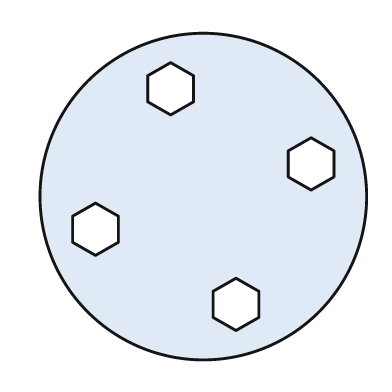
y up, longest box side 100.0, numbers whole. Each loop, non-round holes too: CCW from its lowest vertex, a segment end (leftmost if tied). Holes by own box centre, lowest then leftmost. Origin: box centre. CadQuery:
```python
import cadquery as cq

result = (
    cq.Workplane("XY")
    .moveTo(0.0, 0.0)
    .circle(50.0)
    .moveTo(10.0, -41.0)
    .lineTo(17.0, -37.0)
    .lineTo(17.0, -29.0)
    .lineTo(10.0, -25.0)
    .lineTo(3.0, -29.0)
    .lineTo(3.0, -37.0)
    .close()
    .moveTo(-33.0, -18.0)
    .lineTo(-26.0, -14.0)
    .lineTo(-26.0, -6.0)
    .lineTo(-33.0, -2.0)
    .lineTo(-40.0, -6.0)
    .lineTo(-40.0, -14.0)
    .close()
    .moveTo(33.0, 2.0)
    .lineTo(40.0, 6.0)
    .lineTo(40.0, 14.0)
    .lineTo(33.0, 18.0)
    .lineTo(26.0, 14.0)
    .lineTo(26.0, 6.0)
    .close()
    .moveTo(-10.0, 25.0)
    .lineTo(-3.0, 29.0)
    .lineTo(-3.0, 37.0)
    .lineTo(-10.0, 41.0)
    .lineTo(-17.0, 37.0)
    .lineTo(-17.0, 29.0)
    .close()
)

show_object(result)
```